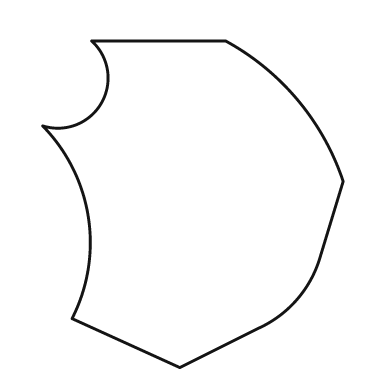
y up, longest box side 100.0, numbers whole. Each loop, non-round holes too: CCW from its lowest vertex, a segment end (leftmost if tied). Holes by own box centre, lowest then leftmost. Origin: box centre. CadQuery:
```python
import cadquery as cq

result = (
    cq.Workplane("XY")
    .moveTo(-4.0, -50.0)
    .lineTo(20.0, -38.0)
    .threePointArc((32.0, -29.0), (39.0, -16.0))
    .lineTo(46.0, 7.0)
    .threePointArc((32.0, 32.0), (10.0, 50.0))
    .lineTo(-31.0, 50.0)
    .threePointArc((-28.0, 31.0), (-46.0, 24.0))
    .threePointArc((-32.0, -4.0), (-37.0, -35.0))
    .close()
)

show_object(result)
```